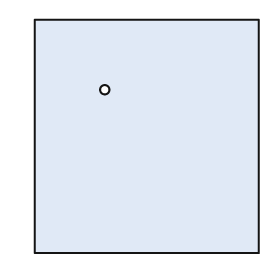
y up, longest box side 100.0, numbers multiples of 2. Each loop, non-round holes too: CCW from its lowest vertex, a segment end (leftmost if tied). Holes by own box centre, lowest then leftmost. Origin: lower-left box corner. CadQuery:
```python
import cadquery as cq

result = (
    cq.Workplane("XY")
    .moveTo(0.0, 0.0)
    .lineTo(96.0, 0.0)
    .lineTo(96.0, 100.0)
    .lineTo(0.0, 100.0)
    .close()
    .moveTo(30.0, 70.0)
    .circle(2.0)
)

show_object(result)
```